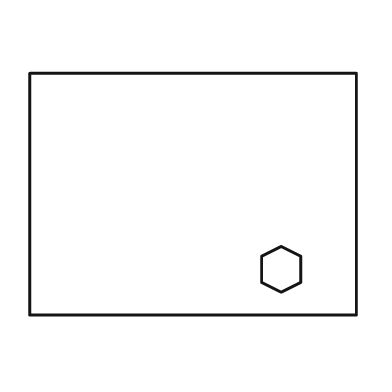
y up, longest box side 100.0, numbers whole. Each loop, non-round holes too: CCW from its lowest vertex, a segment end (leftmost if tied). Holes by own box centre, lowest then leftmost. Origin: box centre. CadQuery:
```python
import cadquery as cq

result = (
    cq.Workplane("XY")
    .moveTo(-50.0, -37.0)
    .lineTo(50.0, -37.0)
    .lineTo(50.0, 37.0)
    .lineTo(-50.0, 37.0)
    .close()
    .moveTo(27.0, -30.0)
    .lineTo(33.0, -27.0)
    .lineTo(33.0, -19.0)
    .lineTo(27.0, -16.0)
    .lineTo(21.0, -19.0)
    .lineTo(21.0, -27.0)
    .close()
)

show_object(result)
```